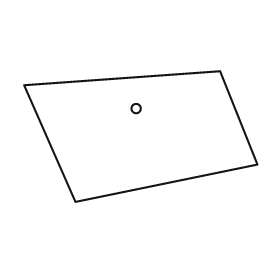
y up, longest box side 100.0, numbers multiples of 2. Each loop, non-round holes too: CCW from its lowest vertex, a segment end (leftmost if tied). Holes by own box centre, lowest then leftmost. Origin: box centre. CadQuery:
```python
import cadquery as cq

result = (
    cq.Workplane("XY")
    .moveTo(-28.0, -28.0)
    .lineTo(50.0, -12.0)
    .lineTo(34.0, 28.0)
    .lineTo(-50.0, 22.0)
    .close()
    .moveTo(-2.0, 12.0)
    .circle(2.0)
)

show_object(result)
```